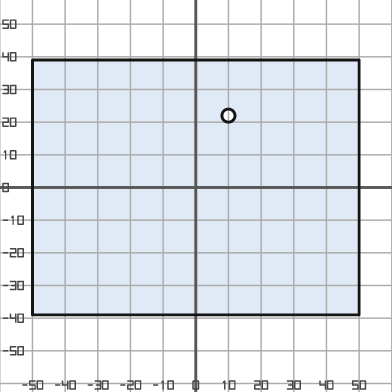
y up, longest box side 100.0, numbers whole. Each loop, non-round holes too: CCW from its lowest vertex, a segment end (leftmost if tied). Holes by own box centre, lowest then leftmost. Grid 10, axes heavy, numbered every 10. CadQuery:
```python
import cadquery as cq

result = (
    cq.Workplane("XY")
    .moveTo(-50.0, -39.0)
    .lineTo(50.0, -39.0)
    .lineTo(50.0, 39.0)
    .lineTo(-50.0, 39.0)
    .close()
    .moveTo(10.0, 22.0)
    .circle(2.0)
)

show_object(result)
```